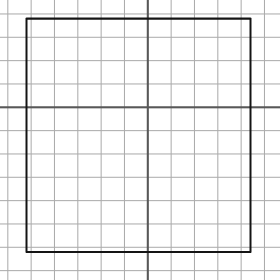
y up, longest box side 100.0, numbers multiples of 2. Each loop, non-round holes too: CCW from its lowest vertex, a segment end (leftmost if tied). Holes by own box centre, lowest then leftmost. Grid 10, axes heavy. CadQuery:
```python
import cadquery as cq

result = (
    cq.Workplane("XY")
    .moveTo(-52.0, -62.0)
    .lineTo(44.0, -62.0)
    .lineTo(44.0, 38.0)
    .lineTo(-52.0, 38.0)
    .close()
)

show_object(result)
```